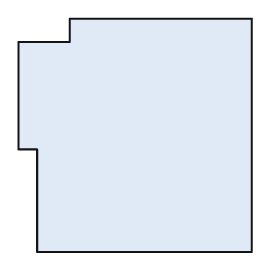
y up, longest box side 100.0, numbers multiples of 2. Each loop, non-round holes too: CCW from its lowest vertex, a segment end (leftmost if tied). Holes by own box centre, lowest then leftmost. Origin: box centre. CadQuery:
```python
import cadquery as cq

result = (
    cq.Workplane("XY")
    .moveTo(-42.0, -50.0)
    .lineTo(50.0, -50.0)
    .lineTo(50.0, 50.0)
    .lineTo(-28.0, 50.0)
    .lineTo(-28.0, 40.0)
    .lineTo(-50.0, 40.0)
    .lineTo(-50.0, -6.0)
    .lineTo(-42.0, -6.0)
    .close()
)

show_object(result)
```